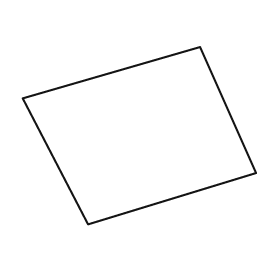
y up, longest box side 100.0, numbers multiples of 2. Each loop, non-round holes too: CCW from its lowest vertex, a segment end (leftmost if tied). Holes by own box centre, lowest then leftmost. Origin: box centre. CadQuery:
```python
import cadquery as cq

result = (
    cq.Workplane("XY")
    .moveTo(-22.0, -38.0)
    .lineTo(50.0, -16.0)
    .lineTo(26.0, 38.0)
    .lineTo(-50.0, 16.0)
    .close()
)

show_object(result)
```